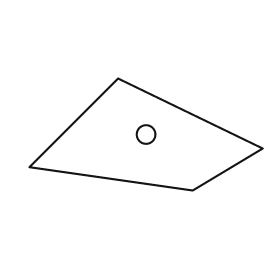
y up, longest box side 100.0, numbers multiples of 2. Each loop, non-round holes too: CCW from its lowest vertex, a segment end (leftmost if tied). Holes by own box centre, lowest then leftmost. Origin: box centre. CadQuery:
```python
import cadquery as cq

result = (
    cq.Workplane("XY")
    .moveTo(20.0, -24.0)
    .lineTo(50.0, -6.0)
    .lineTo(-12.0, 24.0)
    .lineTo(-50.0, -14.0)
    .close()
    .moveTo(0.0, 0.0)
    .circle(4.0)
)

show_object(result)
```